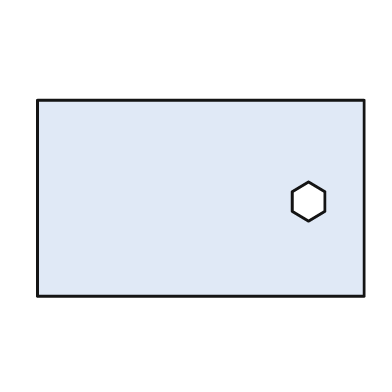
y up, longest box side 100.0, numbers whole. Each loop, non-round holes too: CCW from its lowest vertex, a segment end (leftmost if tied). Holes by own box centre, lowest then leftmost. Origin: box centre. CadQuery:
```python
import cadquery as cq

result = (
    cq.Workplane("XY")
    .moveTo(-50.0, -30.0)
    .lineTo(50.0, -30.0)
    .lineTo(50.0, 30.0)
    .lineTo(-50.0, 30.0)
    .close()
    .moveTo(33.0, -7.0)
    .lineTo(38.0, -4.0)
    .lineTo(38.0, 2.0)
    .lineTo(33.0, 5.0)
    .lineTo(28.0, 2.0)
    .lineTo(28.0, -4.0)
    .close()
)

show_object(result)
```